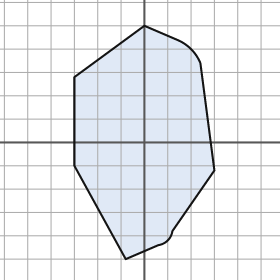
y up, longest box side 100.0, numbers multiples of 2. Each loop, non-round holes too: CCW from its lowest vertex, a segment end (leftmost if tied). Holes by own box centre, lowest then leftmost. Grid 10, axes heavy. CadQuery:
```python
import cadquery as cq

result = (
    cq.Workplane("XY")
    .moveTo(-8.0, -50.0)
    .lineTo(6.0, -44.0)
    .threePointArc((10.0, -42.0), (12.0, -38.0))
    .lineTo(30.0, -12.0)
    .lineTo(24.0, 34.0)
    .threePointArc((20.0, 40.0), (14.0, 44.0))
    .lineTo(0.0, 50.0)
    .lineTo(-30.0, 28.0)
    .lineTo(-30.0, -10.0)
    .close()
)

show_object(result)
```